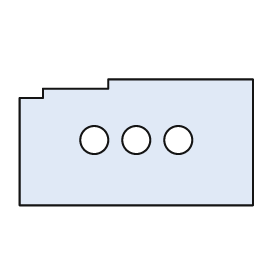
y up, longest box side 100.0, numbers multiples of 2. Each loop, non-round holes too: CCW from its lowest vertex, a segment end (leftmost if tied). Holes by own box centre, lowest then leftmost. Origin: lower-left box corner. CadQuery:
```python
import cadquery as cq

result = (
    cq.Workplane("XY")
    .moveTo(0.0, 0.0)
    .lineTo(100.0, 0.0)
    .lineTo(100.0, 54.0)
    .lineTo(38.0, 54.0)
    .lineTo(38.0, 50.0)
    .lineTo(10.0, 50.0)
    .lineTo(10.0, 46.0)
    .lineTo(0.0, 46.0)
    .close()
    .moveTo(32.0, 28.0)
    .circle(6.0)
    .moveTo(50.0, 28.0)
    .circle(6.0)
    .moveTo(68.0, 28.0)
    .circle(6.0)
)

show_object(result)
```